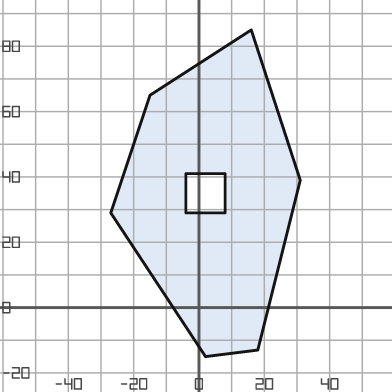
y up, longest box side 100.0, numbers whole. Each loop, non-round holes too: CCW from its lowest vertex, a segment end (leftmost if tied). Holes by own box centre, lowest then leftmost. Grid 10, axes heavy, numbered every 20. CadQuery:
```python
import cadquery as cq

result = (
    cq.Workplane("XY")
    .moveTo(2.0, -15.0)
    .lineTo(18.0, -13.0)
    .lineTo(31.0, 39.0)
    .lineTo(16.0, 85.0)
    .lineTo(-15.0, 65.0)
    .lineTo(-27.0, 29.0)
    .close()
    .moveTo(-4.0, 29.0)
    .lineTo(8.0, 29.0)
    .lineTo(8.0, 41.0)
    .lineTo(-4.0, 41.0)
    .close()
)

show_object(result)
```